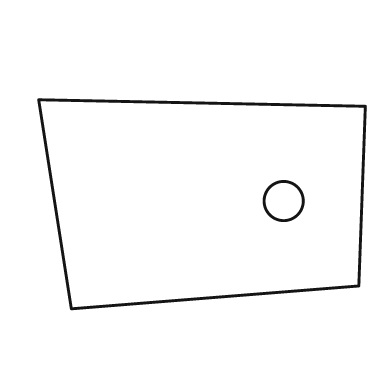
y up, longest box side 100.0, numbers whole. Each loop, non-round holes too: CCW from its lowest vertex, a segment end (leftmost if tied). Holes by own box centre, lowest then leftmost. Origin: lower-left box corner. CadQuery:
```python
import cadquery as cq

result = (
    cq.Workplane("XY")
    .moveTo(10.0, 0.0)
    .lineTo(98.0, 7.0)
    .lineTo(100.0, 62.0)
    .lineTo(0.0, 64.0)
    .close()
    .moveTo(75.0, 33.0)
    .circle(6.0)
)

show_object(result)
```